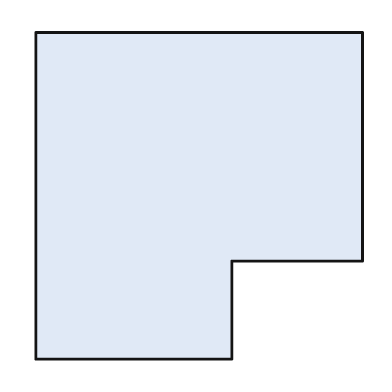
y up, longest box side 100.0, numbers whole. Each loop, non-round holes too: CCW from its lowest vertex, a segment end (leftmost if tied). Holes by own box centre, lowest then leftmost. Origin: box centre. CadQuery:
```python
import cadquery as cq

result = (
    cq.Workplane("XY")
    .moveTo(-50.0, -50.0)
    .lineTo(10.0, -50.0)
    .lineTo(10.0, -20.0)
    .lineTo(50.0, -20.0)
    .lineTo(50.0, 50.0)
    .lineTo(-50.0, 50.0)
    .close()
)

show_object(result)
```